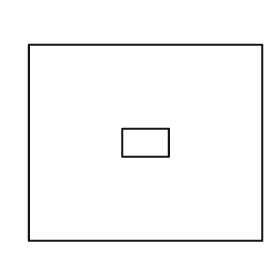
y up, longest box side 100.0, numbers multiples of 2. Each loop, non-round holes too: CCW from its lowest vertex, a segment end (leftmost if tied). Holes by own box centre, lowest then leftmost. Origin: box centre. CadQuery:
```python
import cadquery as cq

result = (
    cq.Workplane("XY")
    .moveTo(-50.0, -42.0)
    .lineTo(50.0, -42.0)
    .lineTo(50.0, 42.0)
    .lineTo(-50.0, 42.0)
    .close()
    .moveTo(-10.0, -6.0)
    .lineTo(10.0, -6.0)
    .lineTo(10.0, 6.0)
    .lineTo(-10.0, 6.0)
    .close()
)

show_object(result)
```